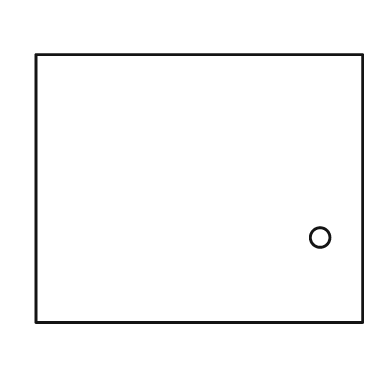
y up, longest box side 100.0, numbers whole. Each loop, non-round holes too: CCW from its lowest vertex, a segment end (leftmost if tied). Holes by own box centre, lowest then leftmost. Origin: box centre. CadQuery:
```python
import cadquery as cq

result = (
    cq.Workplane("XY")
    .moveTo(-50.0, -41.0)
    .lineTo(50.0, -41.0)
    .lineTo(50.0, 41.0)
    .lineTo(-50.0, 41.0)
    .close()
    .moveTo(37.0, -15.0)
    .circle(3.0)
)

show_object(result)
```